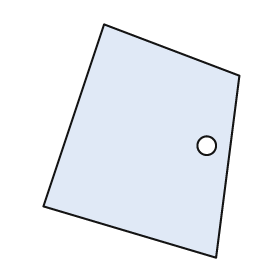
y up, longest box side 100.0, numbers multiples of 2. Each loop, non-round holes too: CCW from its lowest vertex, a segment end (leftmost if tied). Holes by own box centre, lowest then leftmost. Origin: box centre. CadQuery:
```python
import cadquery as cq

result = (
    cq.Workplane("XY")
    .moveTo(32.0, -50.0)
    .lineTo(42.0, 28.0)
    .lineTo(-16.0, 50.0)
    .lineTo(-42.0, -28.0)
    .close()
    .moveTo(28.0, -2.0)
    .circle(4.0)
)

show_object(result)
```